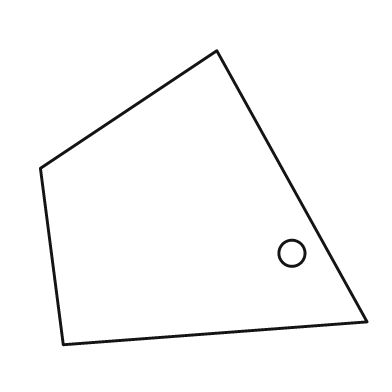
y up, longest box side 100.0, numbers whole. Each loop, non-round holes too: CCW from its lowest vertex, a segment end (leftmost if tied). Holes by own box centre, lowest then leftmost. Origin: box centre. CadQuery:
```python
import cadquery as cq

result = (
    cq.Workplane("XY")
    .moveTo(-43.0, -45.0)
    .lineTo(50.0, -38.0)
    .lineTo(4.0, 45.0)
    .lineTo(-50.0, 9.0)
    .close()
    .moveTo(27.0, -17.0)
    .circle(4.0)
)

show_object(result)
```